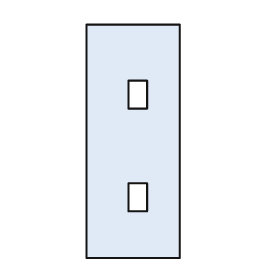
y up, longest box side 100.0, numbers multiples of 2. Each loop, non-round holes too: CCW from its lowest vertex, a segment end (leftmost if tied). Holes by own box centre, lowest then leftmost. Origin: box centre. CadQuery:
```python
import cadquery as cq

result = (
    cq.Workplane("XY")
    .moveTo(-20.0, -50.0)
    .lineTo(20.0, -50.0)
    .lineTo(20.0, 50.0)
    .lineTo(-20.0, 50.0)
    .close()
    .moveTo(-2.0, -30.0)
    .lineTo(6.0, -30.0)
    .lineTo(6.0, -18.0)
    .lineTo(-2.0, -18.0)
    .close()
    .moveTo(-2.0, 14.0)
    .lineTo(6.0, 14.0)
    .lineTo(6.0, 26.0)
    .lineTo(-2.0, 26.0)
    .close()
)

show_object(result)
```